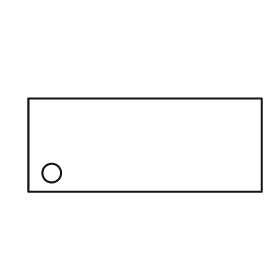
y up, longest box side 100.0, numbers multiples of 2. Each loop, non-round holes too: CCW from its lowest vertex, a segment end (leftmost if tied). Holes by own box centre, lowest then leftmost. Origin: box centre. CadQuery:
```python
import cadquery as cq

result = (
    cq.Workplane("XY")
    .moveTo(-50.0, -20.0)
    .lineTo(50.0, -20.0)
    .lineTo(50.0, 20.0)
    .lineTo(-50.0, 20.0)
    .close()
    .moveTo(-40.0, -12.0)
    .circle(4.0)
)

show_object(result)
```